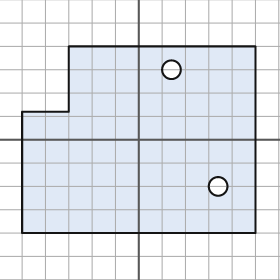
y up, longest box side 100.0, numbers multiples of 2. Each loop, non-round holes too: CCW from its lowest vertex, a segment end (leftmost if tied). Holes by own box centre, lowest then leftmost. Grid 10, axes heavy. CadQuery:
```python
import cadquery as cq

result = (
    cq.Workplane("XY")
    .moveTo(-50.0, -40.0)
    .lineTo(50.0, -40.0)
    .lineTo(50.0, 40.0)
    .lineTo(-30.0, 40.0)
    .lineTo(-30.0, 12.0)
    .lineTo(-50.0, 12.0)
    .close()
    .moveTo(34.0, -20.0)
    .circle(4.0)
    .moveTo(14.0, 30.0)
    .circle(4.0)
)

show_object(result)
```